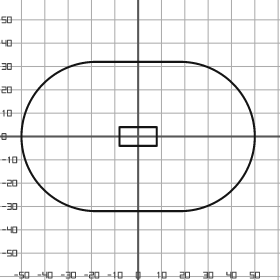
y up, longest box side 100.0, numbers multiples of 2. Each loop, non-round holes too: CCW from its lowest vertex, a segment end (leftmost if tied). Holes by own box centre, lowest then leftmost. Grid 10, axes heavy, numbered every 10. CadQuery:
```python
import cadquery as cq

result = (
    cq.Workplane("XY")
    .moveTo(-18.0, -32.0)
    .lineTo(18.0, -32.0)
    .threePointArc((50.0, 0.0), (18.0, 32.0))
    .lineTo(-18.0, 32.0)
    .threePointArc((-50.0, 0.0), (-18.0, -32.0))
    .close()
    .moveTo(-8.0, -4.0)
    .lineTo(8.0, -4.0)
    .lineTo(8.0, 4.0)
    .lineTo(-8.0, 4.0)
    .close()
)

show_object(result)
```